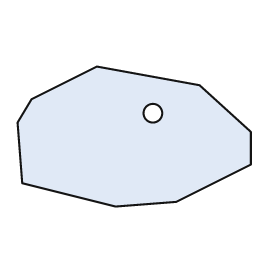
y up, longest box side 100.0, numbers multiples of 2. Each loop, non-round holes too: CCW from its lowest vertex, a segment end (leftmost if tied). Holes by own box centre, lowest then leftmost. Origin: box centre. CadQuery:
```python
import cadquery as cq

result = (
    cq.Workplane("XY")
    .moveTo(-8.0, -30.0)
    .lineTo(18.0, -28.0)
    .lineTo(50.0, -12.0)
    .lineTo(50.0, 2.0)
    .lineTo(28.0, 22.0)
    .lineTo(-16.0, 30.0)
    .lineTo(-44.0, 16.0)
    .lineTo(-50.0, 6.0)
    .lineTo(-48.0, -20.0)
    .close()
    .moveTo(8.0, 10.0)
    .circle(4.0)
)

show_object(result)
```